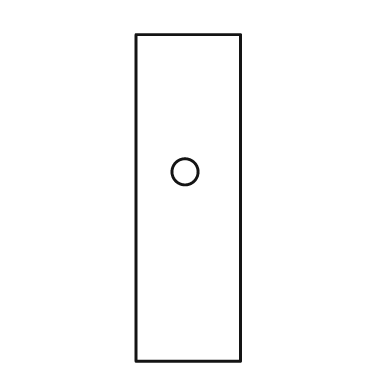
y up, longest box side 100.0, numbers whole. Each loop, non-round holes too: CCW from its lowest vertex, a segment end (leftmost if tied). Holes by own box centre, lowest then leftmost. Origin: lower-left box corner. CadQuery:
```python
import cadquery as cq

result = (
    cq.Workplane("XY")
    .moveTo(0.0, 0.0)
    .lineTo(32.0, 0.0)
    .lineTo(32.0, 100.0)
    .lineTo(0.0, 100.0)
    .close()
    .moveTo(15.0, 58.0)
    .circle(4.0)
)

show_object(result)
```